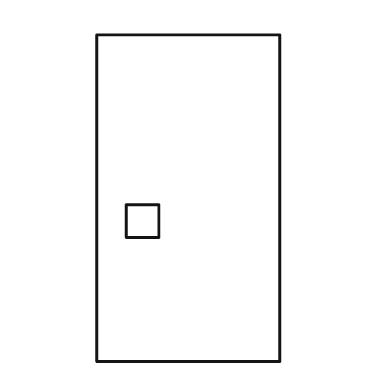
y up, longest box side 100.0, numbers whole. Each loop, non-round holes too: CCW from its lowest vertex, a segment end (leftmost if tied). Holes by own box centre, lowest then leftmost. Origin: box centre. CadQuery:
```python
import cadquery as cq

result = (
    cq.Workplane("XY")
    .moveTo(-28.0, -50.0)
    .lineTo(28.0, -50.0)
    .lineTo(28.0, 50.0)
    .lineTo(-28.0, 50.0)
    .close()
    .moveTo(-19.0, -12.0)
    .lineTo(-9.0, -12.0)
    .lineTo(-9.0, -2.0)
    .lineTo(-19.0, -2.0)
    .close()
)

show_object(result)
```